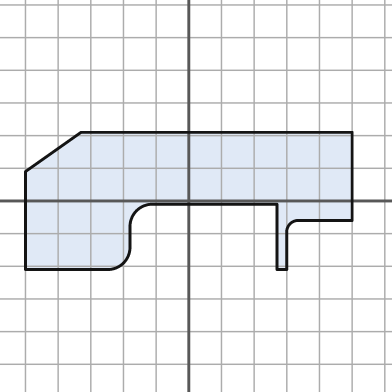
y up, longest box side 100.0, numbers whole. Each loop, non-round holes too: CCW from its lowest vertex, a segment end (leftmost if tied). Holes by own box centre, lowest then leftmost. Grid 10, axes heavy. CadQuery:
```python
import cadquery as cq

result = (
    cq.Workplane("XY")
    .moveTo(-50.0, -21.0)
    .lineTo(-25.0, -21.0)
    .threePointArc((-20.0, -19.0), (-18.0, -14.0))
    .lineTo(-18.0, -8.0)
    .threePointArc((-16.0, -3.0), (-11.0, -1.0))
    .lineTo(27.0, -1.0)
    .lineTo(27.0, -21.0)
    .lineTo(30.0, -21.0)
    .lineTo(30.0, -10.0)
    .threePointArc((31.0, -7.0), (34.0, -6.0))
    .lineTo(50.0, -6.0)
    .lineTo(50.0, 21.0)
    .lineTo(-33.0, 21.0)
    .lineTo(-50.0, 9.0)
    .close()
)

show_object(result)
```